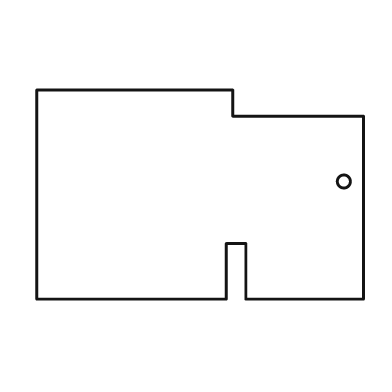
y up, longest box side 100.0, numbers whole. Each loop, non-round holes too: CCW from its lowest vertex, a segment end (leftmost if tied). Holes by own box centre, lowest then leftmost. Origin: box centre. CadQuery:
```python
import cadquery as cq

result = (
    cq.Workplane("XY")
    .moveTo(-50.0, -32.0)
    .lineTo(8.0, -32.0)
    .lineTo(8.0, -15.0)
    .lineTo(14.0, -15.0)
    .lineTo(14.0, -32.0)
    .lineTo(50.0, -32.0)
    .lineTo(50.0, 24.0)
    .lineTo(10.0, 24.0)
    .lineTo(10.0, 32.0)
    .lineTo(-50.0, 32.0)
    .close()
    .moveTo(44.0, 4.0)
    .circle(2.0)
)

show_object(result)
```